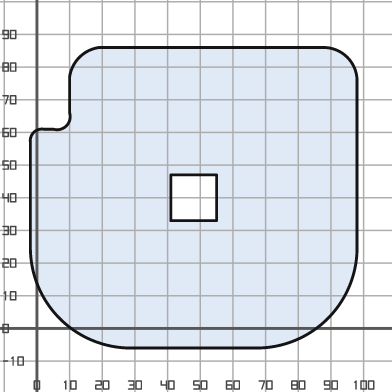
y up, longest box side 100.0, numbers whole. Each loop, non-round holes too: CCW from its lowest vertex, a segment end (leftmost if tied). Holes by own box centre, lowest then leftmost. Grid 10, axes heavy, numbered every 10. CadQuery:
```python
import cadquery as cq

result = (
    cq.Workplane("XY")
    .moveTo(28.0, -6.0)
    .lineTo(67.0, -6.0)
    .threePointArc((89.0, 3.0), (98.0, 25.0))
    .lineTo(98.0, 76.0)
    .threePointArc((95.0, 83.0), (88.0, 86.0))
    .lineTo(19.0, 86.0)
    .threePointArc((13.0, 83.0), (10.0, 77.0))
    .lineTo(10.0, 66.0)
    .threePointArc((9.0, 62.0), (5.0, 61.0))
    .lineTo(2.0, 61.0)
    .threePointArc((-1.0, 60.0), (-2.0, 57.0))
    .lineTo(-2.0, 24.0)
    .threePointArc((7.0, 3.0), (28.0, -6.0))
    .close()
    .moveTo(41.0, 33.0)
    .lineTo(55.0, 33.0)
    .lineTo(55.0, 47.0)
    .lineTo(41.0, 47.0)
    .close()
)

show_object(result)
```